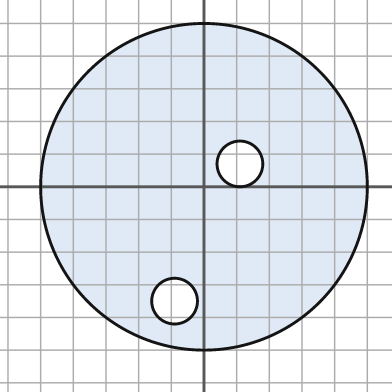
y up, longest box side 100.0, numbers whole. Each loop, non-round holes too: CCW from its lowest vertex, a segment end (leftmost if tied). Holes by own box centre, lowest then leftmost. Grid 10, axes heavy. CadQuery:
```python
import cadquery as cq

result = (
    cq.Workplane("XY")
    .moveTo(0.0, 0.0)
    .circle(50.0)
    .moveTo(-9.0, -35.0)
    .circle(7.0)
    .moveTo(11.0, 7.0)
    .circle(7.0)
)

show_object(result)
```